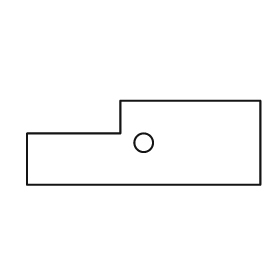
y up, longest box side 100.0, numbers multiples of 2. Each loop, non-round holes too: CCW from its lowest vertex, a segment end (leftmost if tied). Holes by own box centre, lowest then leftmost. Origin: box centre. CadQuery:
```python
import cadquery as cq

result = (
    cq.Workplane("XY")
    .moveTo(-50.0, -18.0)
    .lineTo(50.0, -18.0)
    .lineTo(50.0, 18.0)
    .lineTo(-10.0, 18.0)
    .lineTo(-10.0, 4.0)
    .lineTo(-50.0, 4.0)
    .close()
    .moveTo(0.0, 0.0)
    .circle(4.0)
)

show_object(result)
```